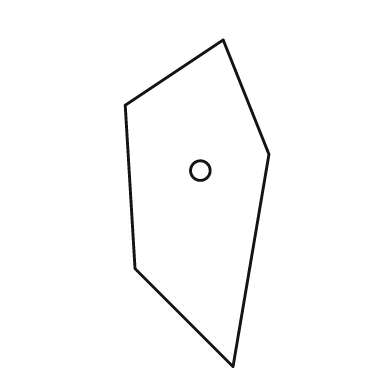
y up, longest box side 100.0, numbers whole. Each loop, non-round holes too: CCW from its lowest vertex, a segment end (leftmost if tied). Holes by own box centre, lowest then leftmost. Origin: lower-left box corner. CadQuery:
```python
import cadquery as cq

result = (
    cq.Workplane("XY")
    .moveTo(33.0, 0.0)
    .lineTo(44.0, 65.0)
    .lineTo(30.0, 100.0)
    .lineTo(0.0, 80.0)
    .lineTo(3.0, 30.0)
    .close()
    .moveTo(23.0, 60.0)
    .circle(3.0)
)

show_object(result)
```